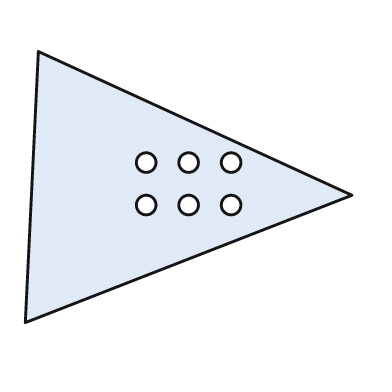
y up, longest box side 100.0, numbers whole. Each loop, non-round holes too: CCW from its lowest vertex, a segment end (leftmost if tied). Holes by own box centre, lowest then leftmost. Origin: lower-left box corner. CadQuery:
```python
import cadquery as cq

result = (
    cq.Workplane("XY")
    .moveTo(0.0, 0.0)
    .lineTo(100.0, 39.0)
    .lineTo(4.0, 83.0)
    .close()
    .moveTo(37.0, 36.0)
    .circle(3.0)
    .moveTo(50.0, 36.0)
    .circle(3.0)
    .moveTo(63.0, 36.0)
    .circle(3.0)
    .moveTo(37.0, 49.0)
    .circle(3.0)
    .moveTo(50.0, 49.0)
    .circle(3.0)
    .moveTo(63.0, 49.0)
    .circle(3.0)
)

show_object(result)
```